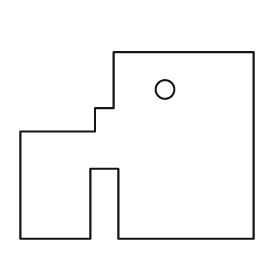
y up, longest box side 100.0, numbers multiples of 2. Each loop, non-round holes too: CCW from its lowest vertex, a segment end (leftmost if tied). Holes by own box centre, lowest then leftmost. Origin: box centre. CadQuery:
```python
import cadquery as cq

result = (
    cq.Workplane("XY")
    .moveTo(-50.0, -40.0)
    .lineTo(-20.0, -40.0)
    .lineTo(-20.0, -10.0)
    .lineTo(-8.0, -10.0)
    .lineTo(-8.0, -40.0)
    .lineTo(50.0, -40.0)
    .lineTo(50.0, 40.0)
    .lineTo(-10.0, 40.0)
    .lineTo(-10.0, 16.0)
    .lineTo(-18.0, 16.0)
    .lineTo(-18.0, 6.0)
    .lineTo(-50.0, 6.0)
    .close()
    .moveTo(12.0, 24.0)
    .circle(4.0)
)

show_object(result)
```